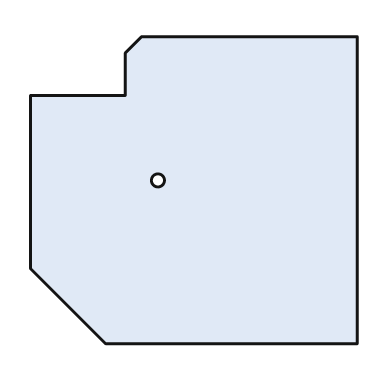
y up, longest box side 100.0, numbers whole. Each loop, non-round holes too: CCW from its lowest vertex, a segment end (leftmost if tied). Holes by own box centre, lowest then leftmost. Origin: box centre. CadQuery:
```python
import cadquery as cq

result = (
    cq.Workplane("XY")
    .moveTo(-27.0, -47.0)
    .lineTo(50.0, -47.0)
    .lineTo(50.0, 47.0)
    .lineTo(-16.0, 47.0)
    .lineTo(-21.0, 42.0)
    .lineTo(-21.0, 29.0)
    .lineTo(-50.0, 29.0)
    .lineTo(-50.0, -24.0)
    .close()
    .moveTo(-11.0, 3.0)
    .circle(2.0)
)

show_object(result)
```